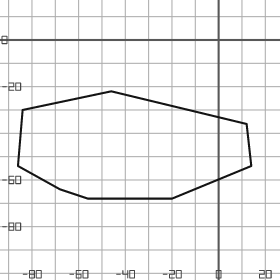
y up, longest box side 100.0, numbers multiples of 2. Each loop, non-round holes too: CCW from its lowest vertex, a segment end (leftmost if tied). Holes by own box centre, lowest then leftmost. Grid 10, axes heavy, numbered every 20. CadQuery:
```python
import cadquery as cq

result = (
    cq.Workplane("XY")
    .moveTo(-56.0, -68.0)
    .lineTo(-20.0, -68.0)
    .lineTo(14.0, -54.0)
    .lineTo(12.0, -36.0)
    .lineTo(-46.0, -22.0)
    .lineTo(-84.0, -30.0)
    .lineTo(-86.0, -54.0)
    .lineTo(-68.0, -64.0)
    .close()
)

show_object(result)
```